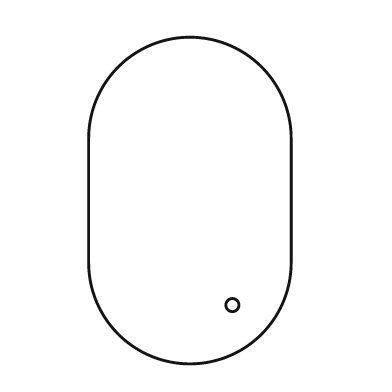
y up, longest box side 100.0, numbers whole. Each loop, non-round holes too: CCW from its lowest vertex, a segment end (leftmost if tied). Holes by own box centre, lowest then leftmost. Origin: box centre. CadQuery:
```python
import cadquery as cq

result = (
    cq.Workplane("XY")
    .moveTo(-31.0, -19.0)
    .threePointArc((0.0, -50.0), (31.0, -19.0))
    .lineTo(31.0, 19.0)
    .threePointArc((0.0, 50.0), (-31.0, 19.0))
    .close()
    .moveTo(13.0, -32.0)
    .circle(2.0)
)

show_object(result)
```